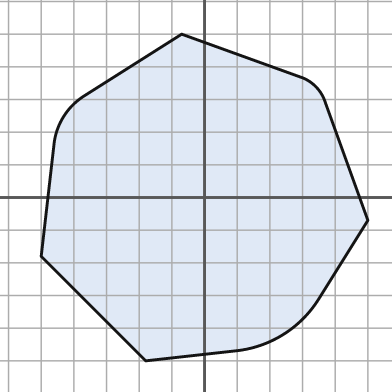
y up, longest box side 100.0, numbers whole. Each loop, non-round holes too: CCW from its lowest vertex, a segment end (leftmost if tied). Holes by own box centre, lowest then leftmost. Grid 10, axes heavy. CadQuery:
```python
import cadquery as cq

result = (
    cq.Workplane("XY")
    .moveTo(-18.0, -50.0)
    .lineTo(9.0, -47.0)
    .threePointArc((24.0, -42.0), (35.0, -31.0))
    .lineTo(50.0, -7.0)
    .lineTo(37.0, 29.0)
    .threePointArc((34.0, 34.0), (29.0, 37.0))
    .lineTo(-7.0, 50.0)
    .lineTo(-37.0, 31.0)
    .threePointArc((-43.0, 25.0), (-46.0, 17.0))
    .lineTo(-50.0, -18.0)
    .close()
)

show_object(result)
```